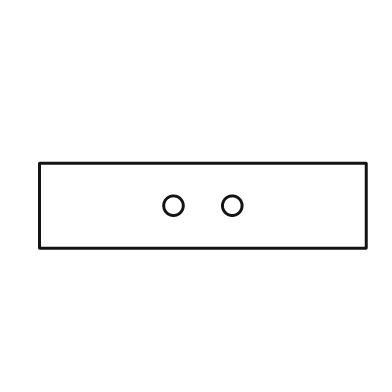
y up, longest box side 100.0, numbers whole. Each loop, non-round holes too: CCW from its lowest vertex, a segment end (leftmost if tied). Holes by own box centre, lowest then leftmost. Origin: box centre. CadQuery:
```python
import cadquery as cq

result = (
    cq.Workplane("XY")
    .moveTo(-50.0, -13.0)
    .lineTo(50.0, -13.0)
    .lineTo(50.0, 13.0)
    .lineTo(-50.0, 13.0)
    .close()
    .moveTo(-9.0, 0.0)
    .circle(3.0)
    .moveTo(9.0, 0.0)
    .circle(3.0)
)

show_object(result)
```